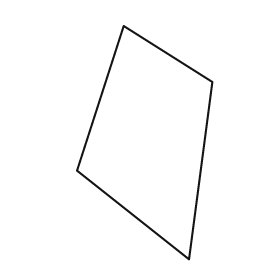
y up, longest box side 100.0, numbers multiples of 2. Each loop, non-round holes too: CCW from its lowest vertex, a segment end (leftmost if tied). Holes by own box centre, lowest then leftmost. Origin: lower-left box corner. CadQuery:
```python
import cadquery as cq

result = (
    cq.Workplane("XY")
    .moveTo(48.0, 0.0)
    .lineTo(58.0, 76.0)
    .lineTo(20.0, 100.0)
    .lineTo(0.0, 38.0)
    .close()
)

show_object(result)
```